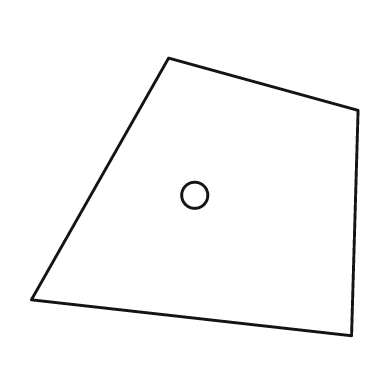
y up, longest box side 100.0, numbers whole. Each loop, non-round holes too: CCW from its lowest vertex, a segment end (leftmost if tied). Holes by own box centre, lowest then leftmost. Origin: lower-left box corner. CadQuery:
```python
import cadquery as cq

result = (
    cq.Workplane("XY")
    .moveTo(98.0, 0.0)
    .lineTo(100.0, 69.0)
    .lineTo(42.0, 85.0)
    .lineTo(0.0, 11.0)
    .close()
    .moveTo(50.0, 43.0)
    .circle(4.0)
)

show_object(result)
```